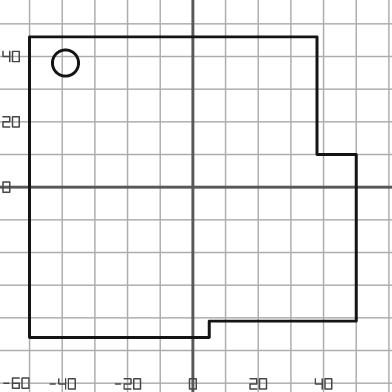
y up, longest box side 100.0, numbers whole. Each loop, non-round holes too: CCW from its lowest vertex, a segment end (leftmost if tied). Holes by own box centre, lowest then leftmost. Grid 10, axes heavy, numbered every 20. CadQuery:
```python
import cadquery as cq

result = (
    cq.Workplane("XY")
    .moveTo(-50.0, -46.0)
    .lineTo(5.0, -46.0)
    .lineTo(5.0, -41.0)
    .lineTo(50.0, -41.0)
    .lineTo(50.0, 10.0)
    .lineTo(38.0, 10.0)
    .lineTo(38.0, 46.0)
    .lineTo(-50.0, 46.0)
    .close()
    .moveTo(-39.0, 38.0)
    .circle(4.0)
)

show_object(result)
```